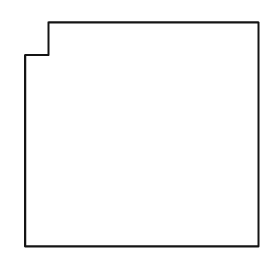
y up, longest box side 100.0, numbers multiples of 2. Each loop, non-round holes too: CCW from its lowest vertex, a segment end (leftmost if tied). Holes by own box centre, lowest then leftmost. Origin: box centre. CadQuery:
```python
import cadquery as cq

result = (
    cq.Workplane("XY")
    .moveTo(-50.0, -48.0)
    .lineTo(50.0, -48.0)
    .lineTo(50.0, 48.0)
    .lineTo(-40.0, 48.0)
    .lineTo(-40.0, 34.0)
    .lineTo(-50.0, 34.0)
    .close()
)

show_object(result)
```